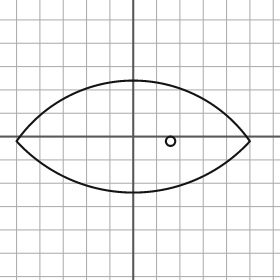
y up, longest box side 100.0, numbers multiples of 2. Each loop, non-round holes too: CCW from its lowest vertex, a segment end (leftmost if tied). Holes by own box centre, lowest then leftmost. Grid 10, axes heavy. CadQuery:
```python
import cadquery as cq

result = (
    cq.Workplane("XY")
    .moveTo(-50.0, -2.0)
    .threePointArc((0.0, -24.0), (50.0, -2.0))
    .threePointArc((0.0, 24.0), (-50.0, -2.0))
    .close()
    .moveTo(16.0, -2.0)
    .circle(2.0)
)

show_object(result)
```